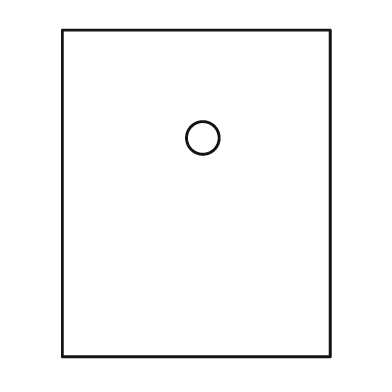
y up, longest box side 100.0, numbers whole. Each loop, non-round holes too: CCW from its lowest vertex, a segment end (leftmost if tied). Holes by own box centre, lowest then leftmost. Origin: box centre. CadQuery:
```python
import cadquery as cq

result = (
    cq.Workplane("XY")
    .moveTo(-41.0, -50.0)
    .lineTo(41.0, -50.0)
    .lineTo(41.0, 50.0)
    .lineTo(-41.0, 50.0)
    .close()
    .moveTo(2.0, 17.0)
    .circle(5.0)
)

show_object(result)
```